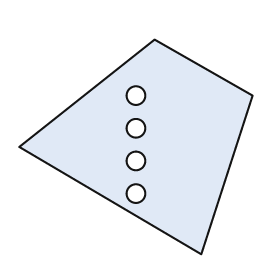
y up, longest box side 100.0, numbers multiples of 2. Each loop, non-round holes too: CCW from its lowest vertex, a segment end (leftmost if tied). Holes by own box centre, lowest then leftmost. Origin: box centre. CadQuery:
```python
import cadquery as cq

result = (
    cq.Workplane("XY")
    .moveTo(28.0, -46.0)
    .lineTo(50.0, 22.0)
    .lineTo(8.0, 46.0)
    .lineTo(-50.0, 0.0)
    .close()
    .moveTo(0.0, -20.0)
    .circle(4.0)
    .moveTo(0.0, -6.0)
    .circle(4.0)
    .moveTo(0.0, 8.0)
    .circle(4.0)
    .moveTo(0.0, 22.0)
    .circle(4.0)
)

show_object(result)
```